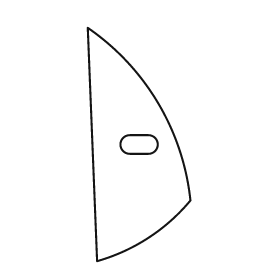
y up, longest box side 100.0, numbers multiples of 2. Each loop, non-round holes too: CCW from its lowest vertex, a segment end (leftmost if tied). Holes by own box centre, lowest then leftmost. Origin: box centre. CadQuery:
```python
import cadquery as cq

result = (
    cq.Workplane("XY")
    .moveTo(-18.0, -50.0)
    .threePointArc((4.0, -40.0), (22.0, -24.0))
    .threePointArc((8.0, 18.0), (-22.0, 50.0))
    .close()
    .moveTo(-4.0, -4.0)
    .lineTo(4.0, -4.0)
    .threePointArc((8.0, 0.0), (4.0, 4.0))
    .lineTo(-4.0, 4.0)
    .threePointArc((-8.0, 0.0), (-4.0, -4.0))
    .close()
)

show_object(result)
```